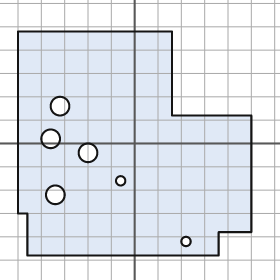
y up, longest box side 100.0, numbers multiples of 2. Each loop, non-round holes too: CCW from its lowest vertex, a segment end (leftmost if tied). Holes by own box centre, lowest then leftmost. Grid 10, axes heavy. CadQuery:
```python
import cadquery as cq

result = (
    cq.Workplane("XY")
    .moveTo(-46.0, -48.0)
    .lineTo(36.0, -48.0)
    .lineTo(36.0, -38.0)
    .lineTo(50.0, -38.0)
    .lineTo(50.0, 12.0)
    .lineTo(16.0, 12.0)
    .lineTo(16.0, 48.0)
    .lineTo(-50.0, 48.0)
    .lineTo(-50.0, -30.0)
    .lineTo(-46.0, -30.0)
    .close()
    .moveTo(22.0, -42.0)
    .circle(2.0)
    .moveTo(-34.0, -22.0)
    .circle(4.0)
    .moveTo(-6.0, -16.0)
    .circle(2.0)
    .moveTo(-20.0, -4.0)
    .circle(4.0)
    .moveTo(-36.0, 2.0)
    .circle(4.0)
    .moveTo(-32.0, 16.0)
    .circle(4.0)
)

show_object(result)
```